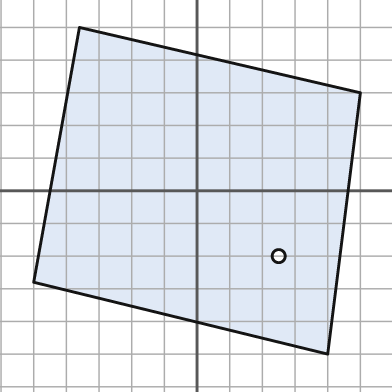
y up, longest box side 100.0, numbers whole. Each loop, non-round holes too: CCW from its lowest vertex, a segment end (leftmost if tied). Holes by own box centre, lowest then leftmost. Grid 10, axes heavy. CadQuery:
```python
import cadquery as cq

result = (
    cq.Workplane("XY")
    .moveTo(40.0, -50.0)
    .lineTo(50.0, 30.0)
    .lineTo(-36.0, 50.0)
    .lineTo(-50.0, -28.0)
    .close()
    .moveTo(25.0, -20.0)
    .circle(2.0)
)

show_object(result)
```